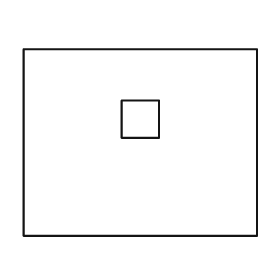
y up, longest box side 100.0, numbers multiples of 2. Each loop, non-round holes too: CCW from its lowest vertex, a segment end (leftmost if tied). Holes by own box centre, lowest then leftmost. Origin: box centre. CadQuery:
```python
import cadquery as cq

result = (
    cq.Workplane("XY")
    .moveTo(-50.0, -40.0)
    .lineTo(50.0, -40.0)
    .lineTo(50.0, 40.0)
    .lineTo(-50.0, 40.0)
    .close()
    .moveTo(-8.0, 2.0)
    .lineTo(8.0, 2.0)
    .lineTo(8.0, 18.0)
    .lineTo(-8.0, 18.0)
    .close()
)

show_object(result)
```